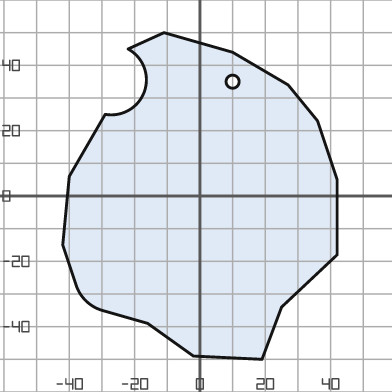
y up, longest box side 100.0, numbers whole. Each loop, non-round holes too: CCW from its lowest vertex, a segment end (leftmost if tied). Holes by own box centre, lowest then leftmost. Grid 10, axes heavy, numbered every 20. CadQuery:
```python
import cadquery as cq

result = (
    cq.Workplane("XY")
    .moveTo(19.0, -50.0)
    .lineTo(25.0, -34.0)
    .lineTo(42.0, -18.0)
    .lineTo(42.0, 5.0)
    .lineTo(36.0, 23.0)
    .lineTo(27.0, 34.0)
    .lineTo(10.0, 44.0)
    .lineTo(-11.0, 50.0)
    .lineTo(-22.0, 45.0)
    .threePointArc((-17.0, 32.0), (-29.0, 25.0))
    .lineTo(-40.0, 6.0)
    .lineTo(-42.0, -15.0)
    .lineTo(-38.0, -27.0)
    .threePointArc((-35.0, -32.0), (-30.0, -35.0))
    .lineTo(-16.0, -39.0)
    .lineTo(-2.0, -49.0)
    .close()
    .moveTo(10.0, 35.0)
    .circle(2.0)
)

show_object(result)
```